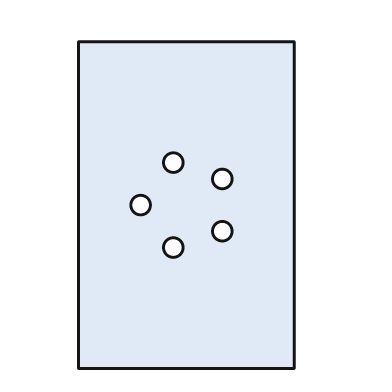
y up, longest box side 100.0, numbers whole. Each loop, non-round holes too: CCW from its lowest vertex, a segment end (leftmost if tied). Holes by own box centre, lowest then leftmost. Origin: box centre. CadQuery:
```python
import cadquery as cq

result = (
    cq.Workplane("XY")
    .moveTo(-33.0, -50.0)
    .lineTo(33.0, -50.0)
    .lineTo(33.0, 50.0)
    .lineTo(-33.0, 50.0)
    .close()
    .moveTo(-4.0, -13.0)
    .circle(3.0)
    .moveTo(11.0, -8.0)
    .circle(3.0)
    .moveTo(-14.0, 0.0)
    .circle(3.0)
    .moveTo(11.0, 8.0)
    .circle(3.0)
    .moveTo(-4.0, 13.0)
    .circle(3.0)
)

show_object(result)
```